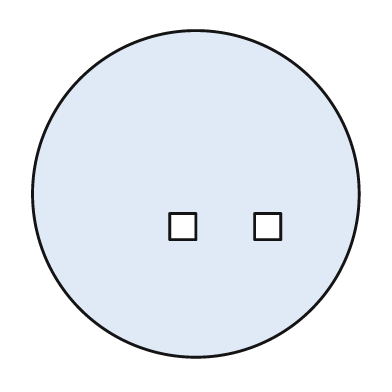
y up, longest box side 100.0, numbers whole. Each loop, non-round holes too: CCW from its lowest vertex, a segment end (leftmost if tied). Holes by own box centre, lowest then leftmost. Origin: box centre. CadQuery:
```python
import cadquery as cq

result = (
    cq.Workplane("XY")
    .moveTo(0.0, 0.0)
    .circle(50.0)
    .moveTo(-8.0, -14.0)
    .lineTo(0.0, -14.0)
    .lineTo(0.0, -6.0)
    .lineTo(-8.0, -6.0)
    .close()
    .moveTo(18.0, -14.0)
    .lineTo(26.0, -14.0)
    .lineTo(26.0, -6.0)
    .lineTo(18.0, -6.0)
    .close()
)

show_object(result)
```